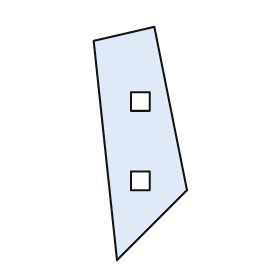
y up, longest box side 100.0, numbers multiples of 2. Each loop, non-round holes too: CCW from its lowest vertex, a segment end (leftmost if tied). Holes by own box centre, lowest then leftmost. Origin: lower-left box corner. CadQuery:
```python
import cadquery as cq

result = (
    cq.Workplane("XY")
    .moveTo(10.0, 0.0)
    .lineTo(40.0, 30.0)
    .lineTo(26.0, 100.0)
    .lineTo(0.0, 94.0)
    .close()
    .moveTo(16.0, 30.0)
    .lineTo(24.0, 30.0)
    .lineTo(24.0, 38.0)
    .lineTo(16.0, 38.0)
    .close()
    .moveTo(16.0, 64.0)
    .lineTo(24.0, 64.0)
    .lineTo(24.0, 72.0)
    .lineTo(16.0, 72.0)
    .close()
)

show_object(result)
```